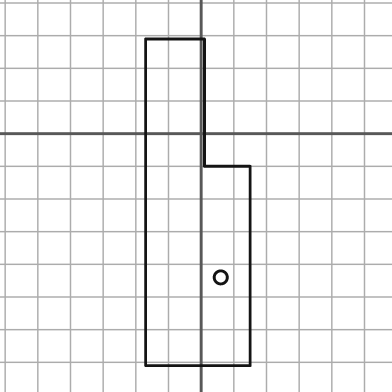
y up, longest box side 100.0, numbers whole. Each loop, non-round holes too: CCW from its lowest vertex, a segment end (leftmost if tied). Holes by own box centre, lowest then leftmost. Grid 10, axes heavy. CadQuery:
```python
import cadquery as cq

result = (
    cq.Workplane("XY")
    .moveTo(-17.0, -71.0)
    .lineTo(15.0, -71.0)
    .lineTo(15.0, -10.0)
    .lineTo(1.0, -10.0)
    .lineTo(1.0, 29.0)
    .lineTo(-17.0, 29.0)
    .close()
    .moveTo(6.0, -44.0)
    .circle(2.0)
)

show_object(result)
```